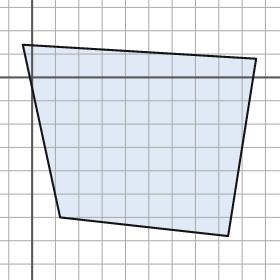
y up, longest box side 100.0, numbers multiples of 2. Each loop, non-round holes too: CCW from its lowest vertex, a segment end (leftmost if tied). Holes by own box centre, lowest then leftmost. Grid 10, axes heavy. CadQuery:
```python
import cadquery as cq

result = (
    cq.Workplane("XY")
    .moveTo(84.0, -68.0)
    .lineTo(96.0, 8.0)
    .lineTo(-4.0, 14.0)
    .lineTo(12.0, -60.0)
    .close()
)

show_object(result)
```